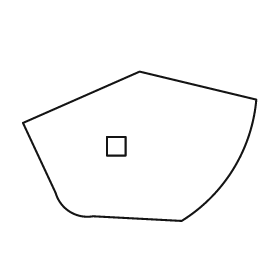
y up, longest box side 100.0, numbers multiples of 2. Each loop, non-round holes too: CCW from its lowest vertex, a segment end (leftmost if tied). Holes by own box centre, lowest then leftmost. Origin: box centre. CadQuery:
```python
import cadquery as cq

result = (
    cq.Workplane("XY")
    .moveTo(18.0, -32.0)
    .threePointArc((40.0, -10.0), (50.0, 20.0))
    .lineTo(0.0, 32.0)
    .lineTo(-50.0, 10.0)
    .lineTo(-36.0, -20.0)
    .threePointArc((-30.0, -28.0), (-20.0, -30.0))
    .close()
    .moveTo(-14.0, -4.0)
    .lineTo(-6.0, -4.0)
    .lineTo(-6.0, 4.0)
    .lineTo(-14.0, 4.0)
    .close()
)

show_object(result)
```